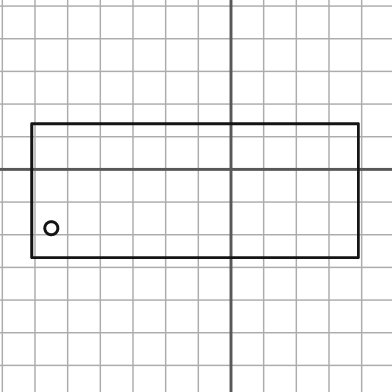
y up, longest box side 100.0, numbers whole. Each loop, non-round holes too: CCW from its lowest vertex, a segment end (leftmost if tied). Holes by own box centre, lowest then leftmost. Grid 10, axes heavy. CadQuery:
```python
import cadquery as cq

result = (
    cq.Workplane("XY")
    .moveTo(-61.0, -27.0)
    .lineTo(39.0, -27.0)
    .lineTo(39.0, 14.0)
    .lineTo(-61.0, 14.0)
    .close()
    .moveTo(-55.0, -18.0)
    .circle(2.0)
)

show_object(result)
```